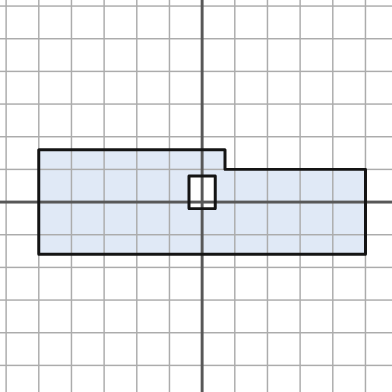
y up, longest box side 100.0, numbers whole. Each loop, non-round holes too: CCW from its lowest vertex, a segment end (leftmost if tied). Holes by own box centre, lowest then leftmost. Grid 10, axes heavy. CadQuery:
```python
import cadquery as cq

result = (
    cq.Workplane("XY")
    .moveTo(-50.0, -16.0)
    .lineTo(50.0, -16.0)
    .lineTo(50.0, 10.0)
    .lineTo(7.0, 10.0)
    .lineTo(7.0, 16.0)
    .lineTo(-50.0, 16.0)
    .close()
    .moveTo(-4.0, -2.0)
    .lineTo(4.0, -2.0)
    .lineTo(4.0, 8.0)
    .lineTo(-4.0, 8.0)
    .close()
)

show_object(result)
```